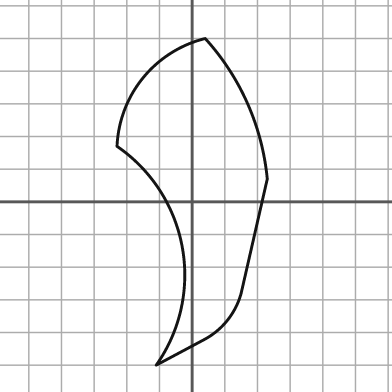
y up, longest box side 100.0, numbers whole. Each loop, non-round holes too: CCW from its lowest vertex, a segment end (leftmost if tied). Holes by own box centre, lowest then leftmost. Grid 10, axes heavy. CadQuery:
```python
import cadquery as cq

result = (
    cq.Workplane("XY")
    .moveTo(-11.0, -50.0)
    .lineTo(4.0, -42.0)
    .threePointArc((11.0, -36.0), (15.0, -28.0))
    .lineTo(23.0, 7.0)
    .threePointArc((17.0, 30.0), (4.0, 50.0))
    .threePointArc((-15.0, 38.0), (-23.0, 17.0))
    .threePointArc((-3.0, -14.0), (-11.0, -50.0))
    .close()
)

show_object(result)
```